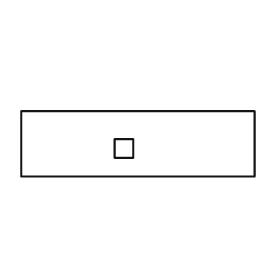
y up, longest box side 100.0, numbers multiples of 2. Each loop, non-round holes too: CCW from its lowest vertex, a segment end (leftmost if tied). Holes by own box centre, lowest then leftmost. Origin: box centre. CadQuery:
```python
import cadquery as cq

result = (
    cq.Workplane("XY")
    .moveTo(-50.0, -14.0)
    .lineTo(50.0, -14.0)
    .lineTo(50.0, 14.0)
    .lineTo(-50.0, 14.0)
    .close()
    .moveTo(-10.0, -6.0)
    .lineTo(-2.0, -6.0)
    .lineTo(-2.0, 2.0)
    .lineTo(-10.0, 2.0)
    .close()
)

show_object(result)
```